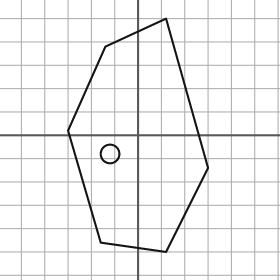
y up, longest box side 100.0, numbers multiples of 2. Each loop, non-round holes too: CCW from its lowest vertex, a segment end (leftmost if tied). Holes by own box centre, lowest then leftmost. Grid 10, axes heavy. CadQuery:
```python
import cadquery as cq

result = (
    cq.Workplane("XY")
    .moveTo(12.0, -50.0)
    .lineTo(30.0, -14.0)
    .lineTo(12.0, 50.0)
    .lineTo(-14.0, 38.0)
    .lineTo(-30.0, 2.0)
    .lineTo(-16.0, -46.0)
    .close()
    .moveTo(-12.0, -8.0)
    .circle(4.0)
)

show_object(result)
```